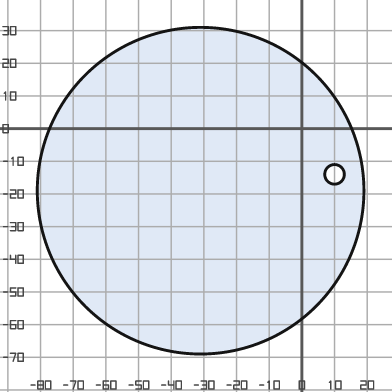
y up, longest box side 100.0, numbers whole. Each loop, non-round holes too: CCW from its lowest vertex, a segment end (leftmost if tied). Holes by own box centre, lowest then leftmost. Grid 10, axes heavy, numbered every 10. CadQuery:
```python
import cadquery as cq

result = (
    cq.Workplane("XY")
    .moveTo(-31.0, -19.0)
    .circle(50.0)
    .moveTo(10.0, -14.0)
    .circle(3.0)
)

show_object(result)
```